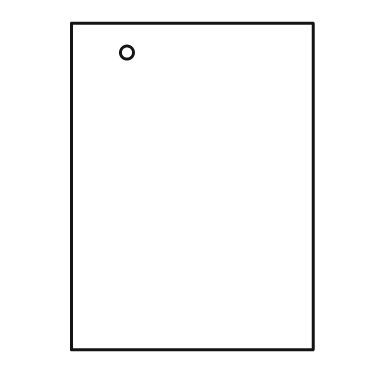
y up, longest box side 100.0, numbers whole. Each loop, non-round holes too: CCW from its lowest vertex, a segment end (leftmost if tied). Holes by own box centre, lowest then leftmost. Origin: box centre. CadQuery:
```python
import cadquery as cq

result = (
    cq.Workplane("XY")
    .moveTo(-37.0, -50.0)
    .lineTo(37.0, -50.0)
    .lineTo(37.0, 50.0)
    .lineTo(-37.0, 50.0)
    .close()
    .moveTo(-20.0, 41.0)
    .circle(2.0)
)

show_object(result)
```